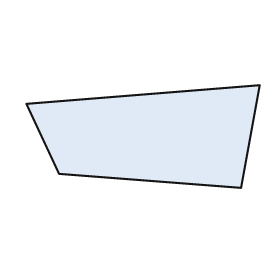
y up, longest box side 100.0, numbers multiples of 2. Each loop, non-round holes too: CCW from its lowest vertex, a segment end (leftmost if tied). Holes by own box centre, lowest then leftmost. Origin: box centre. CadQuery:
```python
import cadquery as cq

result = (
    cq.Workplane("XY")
    .moveTo(42.0, -22.0)
    .lineTo(50.0, 22.0)
    .lineTo(-50.0, 14.0)
    .lineTo(-36.0, -16.0)
    .close()
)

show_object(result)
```